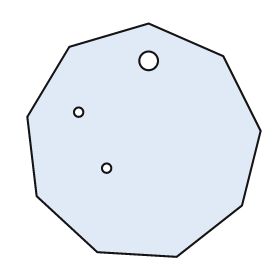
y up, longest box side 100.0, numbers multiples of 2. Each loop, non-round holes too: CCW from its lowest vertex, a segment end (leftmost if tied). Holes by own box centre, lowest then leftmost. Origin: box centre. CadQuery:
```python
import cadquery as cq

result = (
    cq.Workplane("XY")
    .moveTo(14.0, -50.0)
    .lineTo(42.0, -28.0)
    .lineTo(50.0, 4.0)
    .lineTo(34.0, 36.0)
    .lineTo(2.0, 50.0)
    .lineTo(-32.0, 40.0)
    .lineTo(-50.0, 10.0)
    .lineTo(-46.0, -24.0)
    .lineTo(-20.0, -48.0)
    .close()
    .moveTo(-16.0, -12.0)
    .circle(2.0)
    .moveTo(-28.0, 12.0)
    .circle(2.0)
    .moveTo(2.0, 34.0)
    .circle(4.0)
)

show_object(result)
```